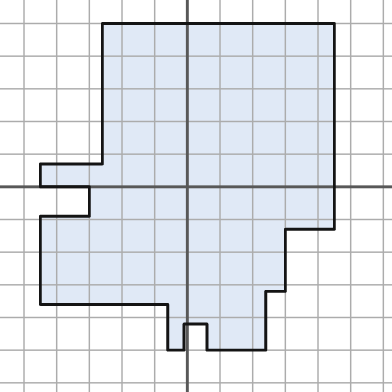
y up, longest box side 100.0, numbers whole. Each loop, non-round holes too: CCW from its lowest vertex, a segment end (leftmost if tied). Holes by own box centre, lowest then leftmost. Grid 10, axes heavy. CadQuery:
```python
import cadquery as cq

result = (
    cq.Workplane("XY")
    .moveTo(-6.0, -50.0)
    .lineTo(-1.0, -50.0)
    .lineTo(-1.0, -42.0)
    .lineTo(6.0, -42.0)
    .lineTo(6.0, -50.0)
    .lineTo(24.0, -50.0)
    .lineTo(24.0, -32.0)
    .lineTo(30.0, -32.0)
    .lineTo(30.0, -13.0)
    .lineTo(45.0, -13.0)
    .lineTo(45.0, 50.0)
    .lineTo(-26.0, 50.0)
    .lineTo(-26.0, 7.0)
    .lineTo(-45.0, 7.0)
    .lineTo(-45.0, 0.0)
    .lineTo(-30.0, 0.0)
    .lineTo(-30.0, -9.0)
    .lineTo(-45.0, -9.0)
    .lineTo(-45.0, -36.0)
    .lineTo(-6.0, -36.0)
    .close()
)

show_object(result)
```